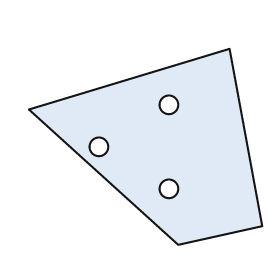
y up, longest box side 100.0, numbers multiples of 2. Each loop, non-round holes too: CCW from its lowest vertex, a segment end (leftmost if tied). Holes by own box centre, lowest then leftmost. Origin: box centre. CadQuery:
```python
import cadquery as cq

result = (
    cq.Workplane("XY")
    .moveTo(14.0, -42.0)
    .lineTo(50.0, -34.0)
    .lineTo(36.0, 42.0)
    .lineTo(-50.0, 16.0)
    .close()
    .moveTo(10.0, -18.0)
    .circle(4.0)
    .moveTo(-20.0, 0.0)
    .circle(4.0)
    .moveTo(10.0, 18.0)
    .circle(4.0)
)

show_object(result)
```